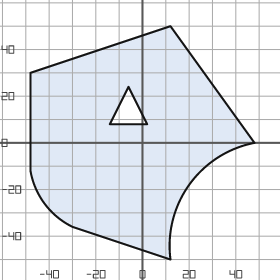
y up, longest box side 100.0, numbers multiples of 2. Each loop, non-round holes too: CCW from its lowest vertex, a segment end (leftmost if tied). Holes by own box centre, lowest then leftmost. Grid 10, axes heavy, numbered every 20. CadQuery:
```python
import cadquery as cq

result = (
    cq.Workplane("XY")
    .moveTo(12.0, -50.0)
    .threePointArc((20.0, -18.0), (48.0, 0.0))
    .lineTo(12.0, 50.0)
    .lineTo(-48.0, 30.0)
    .lineTo(-48.0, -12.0)
    .threePointArc((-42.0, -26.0), (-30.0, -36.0))
    .close()
    .moveTo(-14.0, 8.0)
    .lineTo(2.0, 8.0)
    .lineTo(-6.0, 24.0)
    .close()
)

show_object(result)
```